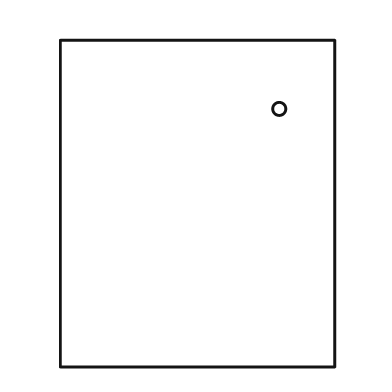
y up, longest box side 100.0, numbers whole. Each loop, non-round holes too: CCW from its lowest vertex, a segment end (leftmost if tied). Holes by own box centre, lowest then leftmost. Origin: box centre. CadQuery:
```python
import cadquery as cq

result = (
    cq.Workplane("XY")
    .moveTo(-42.0, -50.0)
    .lineTo(42.0, -50.0)
    .lineTo(42.0, 50.0)
    .lineTo(-42.0, 50.0)
    .close()
    .moveTo(25.0, 29.0)
    .circle(2.0)
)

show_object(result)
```